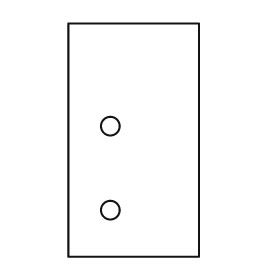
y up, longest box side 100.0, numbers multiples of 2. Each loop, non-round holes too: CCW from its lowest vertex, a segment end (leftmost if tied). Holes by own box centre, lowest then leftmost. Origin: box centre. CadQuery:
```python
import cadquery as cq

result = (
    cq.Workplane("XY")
    .moveTo(-28.0, -50.0)
    .lineTo(28.0, -50.0)
    .lineTo(28.0, 50.0)
    .lineTo(-28.0, 50.0)
    .close()
    .moveTo(-10.0, -30.0)
    .circle(4.0)
    .moveTo(-10.0, 6.0)
    .circle(4.0)
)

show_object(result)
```